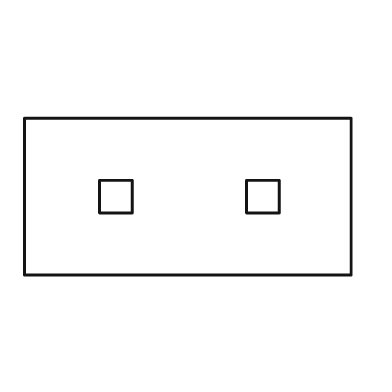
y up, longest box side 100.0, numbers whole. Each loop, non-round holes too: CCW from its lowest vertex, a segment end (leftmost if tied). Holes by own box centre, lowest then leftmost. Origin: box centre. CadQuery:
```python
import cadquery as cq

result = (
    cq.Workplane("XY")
    .moveTo(-50.0, -24.0)
    .lineTo(50.0, -24.0)
    .lineTo(50.0, 24.0)
    .lineTo(-50.0, 24.0)
    .close()
    .moveTo(-27.0, -5.0)
    .lineTo(-17.0, -5.0)
    .lineTo(-17.0, 5.0)
    .lineTo(-27.0, 5.0)
    .close()
    .moveTo(18.0, -5.0)
    .lineTo(28.0, -5.0)
    .lineTo(28.0, 5.0)
    .lineTo(18.0, 5.0)
    .close()
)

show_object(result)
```